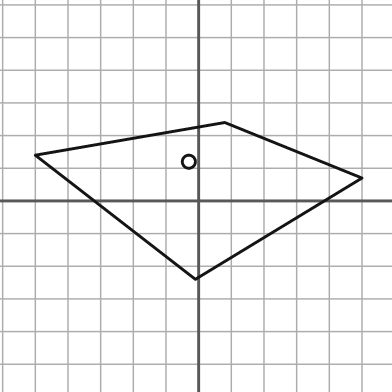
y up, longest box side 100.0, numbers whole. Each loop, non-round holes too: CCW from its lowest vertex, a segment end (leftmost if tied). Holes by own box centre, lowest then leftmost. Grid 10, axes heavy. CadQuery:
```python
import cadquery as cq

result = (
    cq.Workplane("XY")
    .moveTo(-1.0, -24.0)
    .lineTo(50.0, 7.0)
    .lineTo(8.0, 24.0)
    .lineTo(-50.0, 14.0)
    .close()
    .moveTo(-3.0, 12.0)
    .circle(2.0)
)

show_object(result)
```